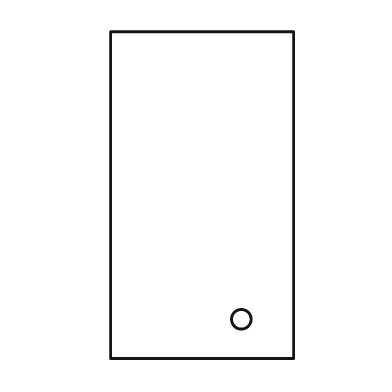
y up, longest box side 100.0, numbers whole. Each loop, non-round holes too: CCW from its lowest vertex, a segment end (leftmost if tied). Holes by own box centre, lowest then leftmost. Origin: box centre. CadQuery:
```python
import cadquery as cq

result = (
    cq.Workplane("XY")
    .moveTo(-28.0, -50.0)
    .lineTo(28.0, -50.0)
    .lineTo(28.0, 50.0)
    .lineTo(-28.0, 50.0)
    .close()
    .moveTo(12.0, -38.0)
    .circle(3.0)
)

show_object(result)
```